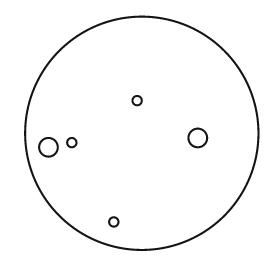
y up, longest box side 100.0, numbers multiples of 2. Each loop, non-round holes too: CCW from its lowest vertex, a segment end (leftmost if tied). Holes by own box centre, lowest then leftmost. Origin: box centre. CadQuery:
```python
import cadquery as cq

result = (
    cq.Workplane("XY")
    .moveTo(0.0, 0.0)
    .circle(50.0)
    .moveTo(-12.0, -38.0)
    .circle(2.0)
    .moveTo(-40.0, -6.0)
    .circle(4.0)
    .moveTo(-30.0, -4.0)
    .circle(2.0)
    .moveTo(24.0, -2.0)
    .circle(4.0)
    .moveTo(-2.0, 14.0)
    .circle(2.0)
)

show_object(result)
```